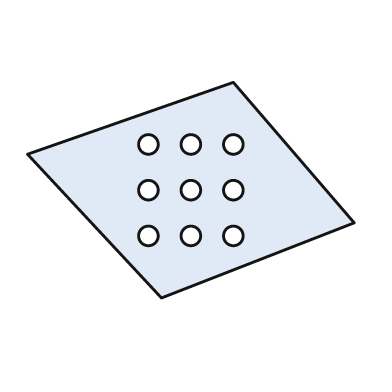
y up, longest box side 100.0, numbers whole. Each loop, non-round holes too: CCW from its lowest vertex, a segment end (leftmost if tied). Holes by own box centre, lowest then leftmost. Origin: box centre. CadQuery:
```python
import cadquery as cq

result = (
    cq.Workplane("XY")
    .moveTo(-9.0, -33.0)
    .lineTo(50.0, -10.0)
    .lineTo(13.0, 33.0)
    .lineTo(-50.0, 11.0)
    .close()
    .moveTo(-13.0, -14.0)
    .circle(3.0)
    .moveTo(0.0, -14.0)
    .circle(3.0)
    .moveTo(13.0, -14.0)
    .circle(3.0)
    .moveTo(-13.0, 0.0)
    .circle(3.0)
    .moveTo(0.0, 0.0)
    .circle(3.0)
    .moveTo(13.0, 0.0)
    .circle(3.0)
    .moveTo(-13.0, 14.0)
    .circle(3.0)
    .moveTo(0.0, 14.0)
    .circle(3.0)
    .moveTo(13.0, 14.0)
    .circle(3.0)
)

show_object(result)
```